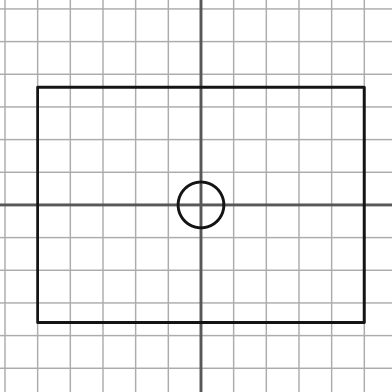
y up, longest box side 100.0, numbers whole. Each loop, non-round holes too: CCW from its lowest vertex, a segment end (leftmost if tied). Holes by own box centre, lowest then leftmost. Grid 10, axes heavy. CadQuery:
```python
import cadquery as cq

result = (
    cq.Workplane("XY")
    .moveTo(-50.0, -36.0)
    .lineTo(50.0, -36.0)
    .lineTo(50.0, 36.0)
    .lineTo(-50.0, 36.0)
    .close()
    .moveTo(0.0, 0.0)
    .circle(7.0)
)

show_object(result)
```